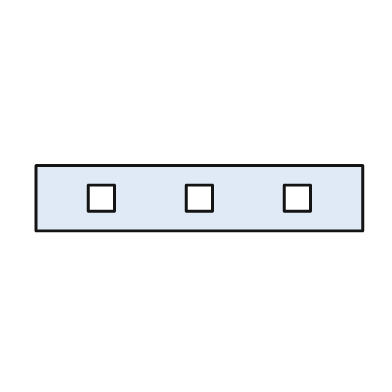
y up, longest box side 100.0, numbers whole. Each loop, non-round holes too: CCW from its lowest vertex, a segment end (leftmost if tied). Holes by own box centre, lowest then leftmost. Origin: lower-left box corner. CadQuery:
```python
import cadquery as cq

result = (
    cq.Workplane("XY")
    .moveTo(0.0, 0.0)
    .lineTo(100.0, 0.0)
    .lineTo(100.0, 20.0)
    .lineTo(0.0, 20.0)
    .close()
    .moveTo(16.0, 6.0)
    .lineTo(24.0, 6.0)
    .lineTo(24.0, 14.0)
    .lineTo(16.0, 14.0)
    .close()
    .moveTo(46.0, 6.0)
    .lineTo(54.0, 6.0)
    .lineTo(54.0, 14.0)
    .lineTo(46.0, 14.0)
    .close()
    .moveTo(76.0, 6.0)
    .lineTo(84.0, 6.0)
    .lineTo(84.0, 14.0)
    .lineTo(76.0, 14.0)
    .close()
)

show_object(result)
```